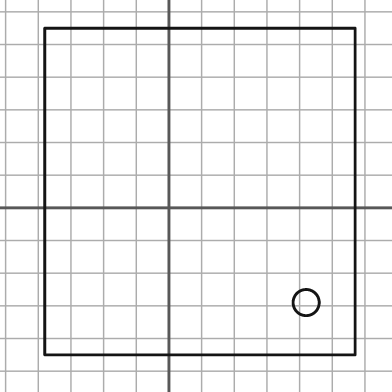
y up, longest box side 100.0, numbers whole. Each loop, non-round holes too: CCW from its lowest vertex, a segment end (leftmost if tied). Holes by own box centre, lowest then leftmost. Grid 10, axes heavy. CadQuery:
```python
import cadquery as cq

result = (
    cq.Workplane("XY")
    .moveTo(-38.0, -45.0)
    .lineTo(57.0, -45.0)
    .lineTo(57.0, 55.0)
    .lineTo(-38.0, 55.0)
    .close()
    .moveTo(42.0, -29.0)
    .circle(4.0)
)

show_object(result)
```